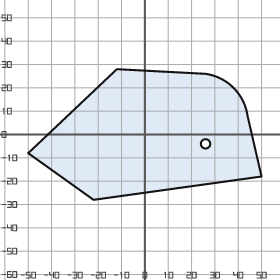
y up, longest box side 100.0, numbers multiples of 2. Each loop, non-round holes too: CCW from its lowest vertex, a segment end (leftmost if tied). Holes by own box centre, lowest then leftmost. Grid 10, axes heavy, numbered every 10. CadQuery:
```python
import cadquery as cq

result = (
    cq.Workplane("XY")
    .moveTo(-22.0, -28.0)
    .lineTo(50.0, -18.0)
    .lineTo(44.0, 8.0)
    .threePointArc((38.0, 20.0), (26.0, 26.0))
    .lineTo(-12.0, 28.0)
    .lineTo(-50.0, -8.0)
    .close()
    .moveTo(26.0, -4.0)
    .circle(2.0)
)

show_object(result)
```